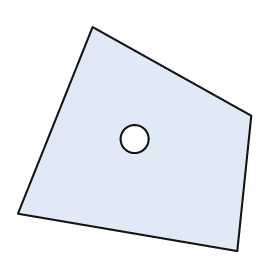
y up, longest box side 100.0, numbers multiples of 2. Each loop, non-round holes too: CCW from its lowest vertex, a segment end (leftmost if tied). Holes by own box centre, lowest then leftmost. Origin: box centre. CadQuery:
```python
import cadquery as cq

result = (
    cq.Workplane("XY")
    .moveTo(44.0, -48.0)
    .lineTo(50.0, 10.0)
    .lineTo(-18.0, 48.0)
    .lineTo(-50.0, -32.0)
    .close()
    .moveTo(0.0, 0.0)
    .circle(6.0)
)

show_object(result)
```